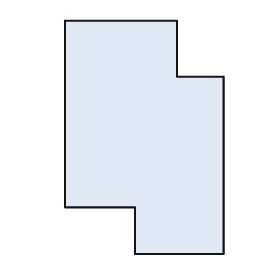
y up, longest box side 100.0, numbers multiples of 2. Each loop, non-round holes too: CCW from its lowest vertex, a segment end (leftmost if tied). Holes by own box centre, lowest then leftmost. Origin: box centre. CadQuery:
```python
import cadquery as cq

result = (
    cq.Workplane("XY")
    .moveTo(-4.0, -50.0)
    .lineTo(34.0, -50.0)
    .lineTo(34.0, 26.0)
    .lineTo(14.0, 26.0)
    .lineTo(14.0, 50.0)
    .lineTo(-34.0, 50.0)
    .lineTo(-34.0, -30.0)
    .lineTo(-4.0, -30.0)
    .close()
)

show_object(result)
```